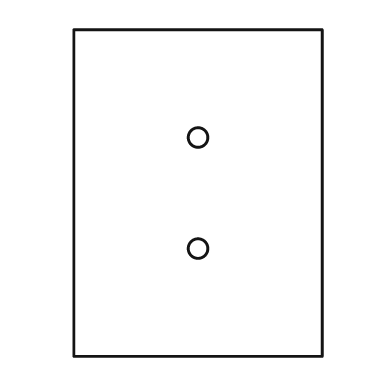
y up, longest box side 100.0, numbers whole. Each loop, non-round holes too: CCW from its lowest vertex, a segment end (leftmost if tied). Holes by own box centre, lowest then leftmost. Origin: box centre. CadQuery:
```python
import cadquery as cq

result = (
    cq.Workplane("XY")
    .moveTo(-38.0, -50.0)
    .lineTo(38.0, -50.0)
    .lineTo(38.0, 50.0)
    .lineTo(-38.0, 50.0)
    .close()
    .moveTo(0.0, -17.0)
    .circle(3.0)
    .moveTo(0.0, 17.0)
    .circle(3.0)
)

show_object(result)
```